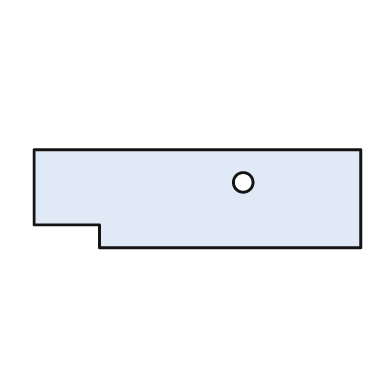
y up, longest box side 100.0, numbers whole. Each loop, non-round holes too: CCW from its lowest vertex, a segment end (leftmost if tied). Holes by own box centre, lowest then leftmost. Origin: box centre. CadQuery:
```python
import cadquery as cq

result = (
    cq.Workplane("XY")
    .moveTo(-30.0, -15.0)
    .lineTo(50.0, -15.0)
    .lineTo(50.0, 15.0)
    .lineTo(-50.0, 15.0)
    .lineTo(-50.0, -8.0)
    .lineTo(-30.0, -8.0)
    .close()
    .moveTo(14.0, 5.0)
    .circle(3.0)
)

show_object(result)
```